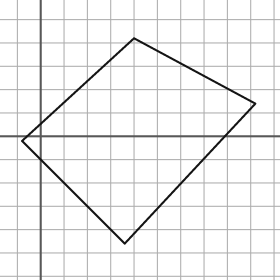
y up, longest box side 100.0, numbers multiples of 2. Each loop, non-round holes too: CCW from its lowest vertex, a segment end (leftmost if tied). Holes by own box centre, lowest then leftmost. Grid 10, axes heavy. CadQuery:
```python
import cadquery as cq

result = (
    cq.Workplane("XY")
    .moveTo(36.0, -46.0)
    .lineTo(92.0, 14.0)
    .lineTo(40.0, 42.0)
    .lineTo(-8.0, -2.0)
    .close()
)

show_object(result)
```